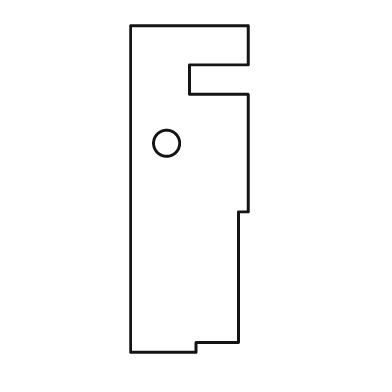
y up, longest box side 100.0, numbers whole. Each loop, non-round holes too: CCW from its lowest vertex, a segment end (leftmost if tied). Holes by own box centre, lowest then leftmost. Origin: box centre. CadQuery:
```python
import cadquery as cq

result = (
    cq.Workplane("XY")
    .moveTo(-18.0, -50.0)
    .lineTo(2.0, -50.0)
    .lineTo(2.0, -47.0)
    .lineTo(15.0, -47.0)
    .lineTo(15.0, -7.0)
    .lineTo(18.0, -7.0)
    .lineTo(18.0, 29.0)
    .lineTo(0.0, 29.0)
    .lineTo(0.0, 38.0)
    .lineTo(18.0, 38.0)
    .lineTo(18.0, 50.0)
    .lineTo(-18.0, 50.0)
    .close()
    .moveTo(-7.0, 14.0)
    .circle(4.0)
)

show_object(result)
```